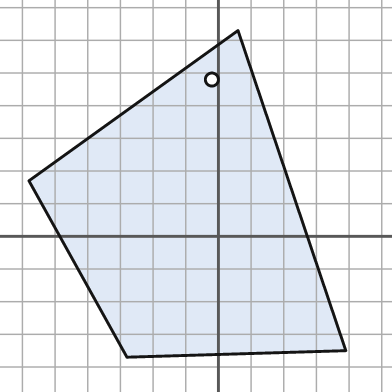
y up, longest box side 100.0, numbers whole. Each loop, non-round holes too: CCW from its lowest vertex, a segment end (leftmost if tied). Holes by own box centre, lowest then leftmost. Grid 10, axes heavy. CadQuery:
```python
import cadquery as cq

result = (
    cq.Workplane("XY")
    .moveTo(-28.0, -37.0)
    .lineTo(39.0, -35.0)
    .lineTo(6.0, 63.0)
    .lineTo(-58.0, 17.0)
    .close()
    .moveTo(-2.0, 48.0)
    .circle(2.0)
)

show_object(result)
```